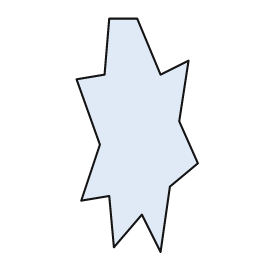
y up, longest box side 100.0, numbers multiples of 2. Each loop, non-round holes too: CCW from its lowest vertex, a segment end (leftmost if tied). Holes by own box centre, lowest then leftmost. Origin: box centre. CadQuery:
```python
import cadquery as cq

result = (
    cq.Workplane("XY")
    .moveTo(10.0, -50.0)
    .lineTo(14.0, -22.0)
    .lineTo(26.0, -12.0)
    .lineTo(18.0, 6.0)
    .lineTo(22.0, 32.0)
    .lineTo(10.0, 26.0)
    .lineTo(0.0, 50.0)
    .lineTo(-12.0, 50.0)
    .lineTo(-14.0, 26.0)
    .lineTo(-26.0, 24.0)
    .lineTo(-16.0, -4.0)
    .lineTo(-24.0, -28.0)
    .lineTo(-12.0, -26.0)
    .lineTo(-10.0, -48.0)
    .lineTo(2.0, -34.0)
    .close()
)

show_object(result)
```